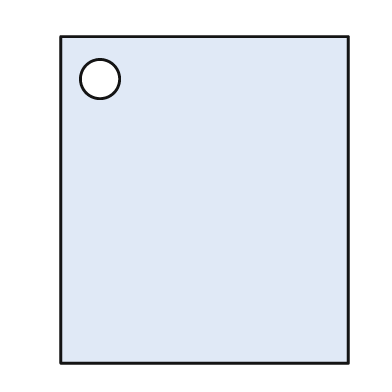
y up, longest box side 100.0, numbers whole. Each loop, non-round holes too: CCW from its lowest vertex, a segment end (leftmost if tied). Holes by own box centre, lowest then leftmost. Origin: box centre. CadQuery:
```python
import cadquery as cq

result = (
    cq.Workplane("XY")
    .moveTo(-44.0, -50.0)
    .lineTo(44.0, -50.0)
    .lineTo(44.0, 50.0)
    .lineTo(-44.0, 50.0)
    .close()
    .moveTo(-32.0, 37.0)
    .circle(6.0)
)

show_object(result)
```